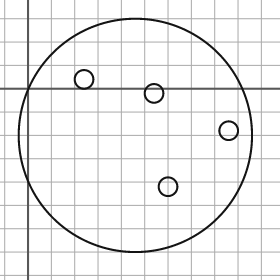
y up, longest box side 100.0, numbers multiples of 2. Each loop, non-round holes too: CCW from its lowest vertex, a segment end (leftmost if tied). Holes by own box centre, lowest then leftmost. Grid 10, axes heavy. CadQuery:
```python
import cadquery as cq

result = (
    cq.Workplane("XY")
    .moveTo(46.0, -20.0)
    .circle(50.0)
    .moveTo(60.0, -42.0)
    .circle(4.0)
    .moveTo(86.0, -18.0)
    .circle(4.0)
    .moveTo(54.0, -2.0)
    .circle(4.0)
    .moveTo(24.0, 4.0)
    .circle(4.0)
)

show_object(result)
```